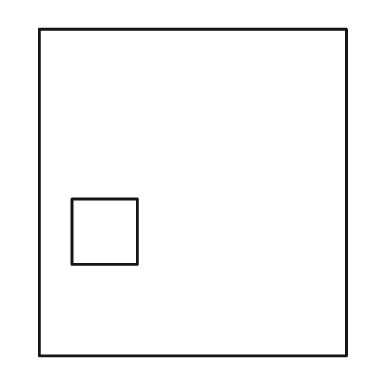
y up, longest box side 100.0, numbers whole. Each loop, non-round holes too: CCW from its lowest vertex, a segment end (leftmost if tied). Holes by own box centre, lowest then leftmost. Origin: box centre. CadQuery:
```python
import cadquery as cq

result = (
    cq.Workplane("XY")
    .moveTo(-47.0, -50.0)
    .lineTo(47.0, -50.0)
    .lineTo(47.0, 50.0)
    .lineTo(-47.0, 50.0)
    .close()
    .moveTo(-37.0, -22.0)
    .lineTo(-17.0, -22.0)
    .lineTo(-17.0, -2.0)
    .lineTo(-37.0, -2.0)
    .close()
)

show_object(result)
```